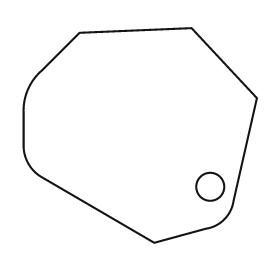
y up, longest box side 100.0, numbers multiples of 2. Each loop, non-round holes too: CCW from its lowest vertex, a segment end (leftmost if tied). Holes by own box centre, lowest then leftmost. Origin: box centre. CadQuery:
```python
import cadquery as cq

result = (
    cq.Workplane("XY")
    .moveTo(6.0, -46.0)
    .lineTo(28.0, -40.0)
    .threePointArc((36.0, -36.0), (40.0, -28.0))
    .lineTo(50.0, 16.0)
    .lineTo(22.0, 46.0)
    .lineTo(-26.0, 44.0)
    .lineTo(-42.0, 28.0)
    .threePointArc((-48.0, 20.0), (-50.0, 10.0))
    .lineTo(-50.0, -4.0)
    .threePointArc((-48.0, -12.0), (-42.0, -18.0))
    .close()
    .moveTo(30.0, -22.0)
    .circle(6.0)
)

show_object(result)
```